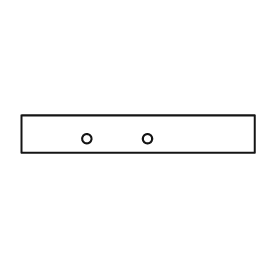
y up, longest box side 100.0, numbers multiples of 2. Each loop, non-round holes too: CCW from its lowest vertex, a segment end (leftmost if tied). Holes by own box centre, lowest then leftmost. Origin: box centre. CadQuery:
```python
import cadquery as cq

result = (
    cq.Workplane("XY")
    .moveTo(-50.0, -8.0)
    .lineTo(50.0, -8.0)
    .lineTo(50.0, 8.0)
    .lineTo(-50.0, 8.0)
    .close()
    .moveTo(-22.0, -2.0)
    .circle(2.0)
    .moveTo(4.0, -2.0)
    .circle(2.0)
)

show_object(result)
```